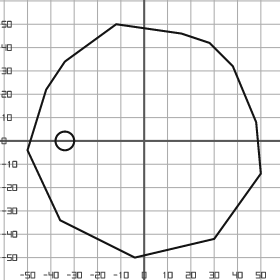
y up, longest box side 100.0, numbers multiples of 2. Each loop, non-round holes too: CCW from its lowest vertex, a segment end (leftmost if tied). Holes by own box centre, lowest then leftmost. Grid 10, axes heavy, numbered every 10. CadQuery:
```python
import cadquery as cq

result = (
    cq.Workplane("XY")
    .moveTo(-4.0, -50.0)
    .lineTo(30.0, -42.0)
    .lineTo(50.0, -14.0)
    .lineTo(48.0, 8.0)
    .lineTo(38.0, 32.0)
    .lineTo(28.0, 42.0)
    .lineTo(16.0, 46.0)
    .lineTo(-12.0, 50.0)
    .lineTo(-34.0, 34.0)
    .lineTo(-42.0, 22.0)
    .lineTo(-50.0, -4.0)
    .lineTo(-36.0, -34.0)
    .close()
    .moveTo(-34.0, 0.0)
    .circle(4.0)
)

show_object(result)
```